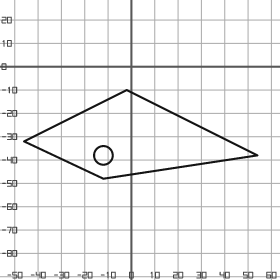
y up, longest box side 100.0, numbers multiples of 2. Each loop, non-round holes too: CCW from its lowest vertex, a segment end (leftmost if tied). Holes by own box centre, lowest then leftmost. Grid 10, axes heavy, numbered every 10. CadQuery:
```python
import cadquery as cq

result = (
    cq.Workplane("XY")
    .moveTo(-12.0, -48.0)
    .lineTo(54.0, -38.0)
    .lineTo(-2.0, -10.0)
    .lineTo(-46.0, -32.0)
    .close()
    .moveTo(-12.0, -38.0)
    .circle(4.0)
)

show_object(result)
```